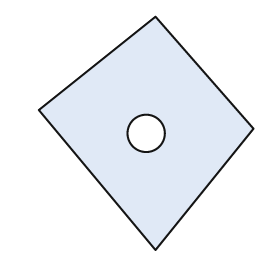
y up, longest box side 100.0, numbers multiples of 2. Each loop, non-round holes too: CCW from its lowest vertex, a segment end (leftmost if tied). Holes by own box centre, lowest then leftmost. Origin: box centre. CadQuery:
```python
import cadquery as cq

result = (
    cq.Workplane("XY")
    .moveTo(4.0, -50.0)
    .lineTo(46.0, 2.0)
    .lineTo(4.0, 50.0)
    .lineTo(-46.0, 10.0)
    .close()
    .moveTo(0.0, 0.0)
    .circle(8.0)
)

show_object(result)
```